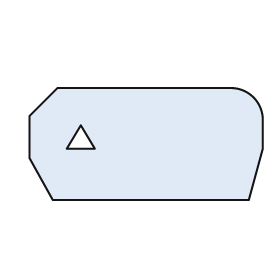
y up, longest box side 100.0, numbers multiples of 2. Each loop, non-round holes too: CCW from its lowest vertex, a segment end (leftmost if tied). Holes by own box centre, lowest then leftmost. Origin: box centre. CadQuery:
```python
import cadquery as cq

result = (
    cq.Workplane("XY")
    .moveTo(-40.0, -24.0)
    .lineTo(44.0, -24.0)
    .lineTo(50.0, -2.0)
    .lineTo(50.0, 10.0)
    .threePointArc((46.0, 20.0), (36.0, 24.0))
    .lineTo(-38.0, 24.0)
    .lineTo(-50.0, 12.0)
    .lineTo(-50.0, -6.0)
    .close()
    .moveTo(-34.0, -2.0)
    .lineTo(-22.0, -2.0)
    .lineTo(-28.0, 8.0)
    .close()
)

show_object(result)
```